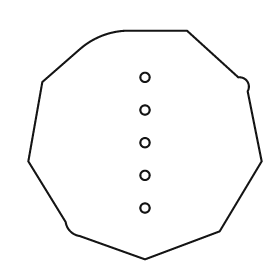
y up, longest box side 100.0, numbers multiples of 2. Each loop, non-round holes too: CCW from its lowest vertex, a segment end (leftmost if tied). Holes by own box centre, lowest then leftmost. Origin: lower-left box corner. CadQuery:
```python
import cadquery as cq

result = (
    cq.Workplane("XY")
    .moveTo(50.0, 0.0)
    .lineTo(82.0, 12.0)
    .lineTo(100.0, 42.0)
    .lineTo(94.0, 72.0)
    .threePointArc((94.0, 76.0), (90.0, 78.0))
    .lineTo(68.0, 98.0)
    .lineTo(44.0, 98.0)
    .threePointArc((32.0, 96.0), (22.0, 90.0))
    .lineTo(6.0, 76.0)
    .lineTo(0.0, 42.0)
    .lineTo(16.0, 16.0)
    .threePointArc((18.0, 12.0), (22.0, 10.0))
    .close()
    .moveTo(50.0, 22.0)
    .circle(2.0)
    .moveTo(50.0, 36.0)
    .circle(2.0)
    .moveTo(50.0, 50.0)
    .circle(2.0)
    .moveTo(50.0, 64.0)
    .circle(2.0)
    .moveTo(50.0, 78.0)
    .circle(2.0)
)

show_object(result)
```